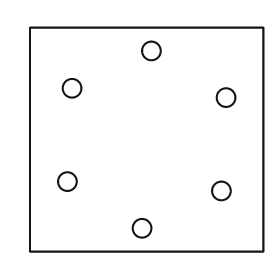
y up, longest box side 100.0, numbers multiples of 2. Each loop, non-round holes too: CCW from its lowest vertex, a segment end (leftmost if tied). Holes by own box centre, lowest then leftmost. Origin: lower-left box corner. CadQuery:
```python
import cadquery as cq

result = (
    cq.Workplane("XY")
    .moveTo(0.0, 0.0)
    .lineTo(100.0, 0.0)
    .lineTo(100.0, 96.0)
    .lineTo(0.0, 96.0)
    .close()
    .moveTo(48.0, 10.0)
    .circle(4.0)
    .moveTo(82.0, 26.0)
    .circle(4.0)
    .moveTo(16.0, 30.0)
    .circle(4.0)
    .moveTo(84.0, 66.0)
    .circle(4.0)
    .moveTo(18.0, 70.0)
    .circle(4.0)
    .moveTo(52.0, 86.0)
    .circle(4.0)
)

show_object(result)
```